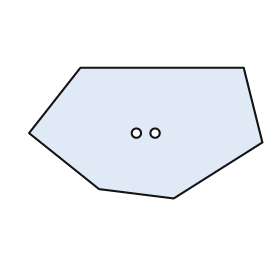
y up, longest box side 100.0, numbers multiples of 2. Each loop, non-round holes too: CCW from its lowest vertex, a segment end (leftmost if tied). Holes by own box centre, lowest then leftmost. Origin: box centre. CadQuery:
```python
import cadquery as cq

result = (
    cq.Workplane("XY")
    .moveTo(12.0, -28.0)
    .lineTo(50.0, -4.0)
    .lineTo(42.0, 28.0)
    .lineTo(-28.0, 28.0)
    .lineTo(-50.0, 0.0)
    .lineTo(-20.0, -24.0)
    .close()
    .moveTo(-4.0, 0.0)
    .circle(2.0)
    .moveTo(4.0, 0.0)
    .circle(2.0)
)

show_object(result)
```